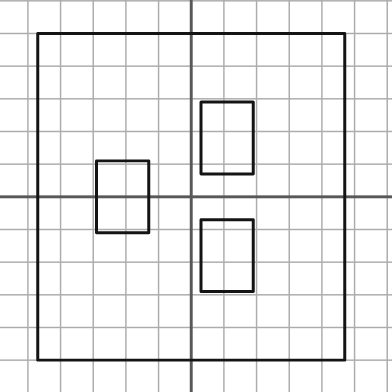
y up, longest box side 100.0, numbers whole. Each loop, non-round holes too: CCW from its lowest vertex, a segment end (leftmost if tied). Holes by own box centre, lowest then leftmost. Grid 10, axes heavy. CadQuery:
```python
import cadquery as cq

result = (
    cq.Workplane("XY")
    .moveTo(-47.0, -50.0)
    .lineTo(47.0, -50.0)
    .lineTo(47.0, 50.0)
    .lineTo(-47.0, 50.0)
    .close()
    .moveTo(3.0, -29.0)
    .lineTo(19.0, -29.0)
    .lineTo(19.0, -7.0)
    .lineTo(3.0, -7.0)
    .close()
    .moveTo(-29.0, -11.0)
    .lineTo(-13.0, -11.0)
    .lineTo(-13.0, 11.0)
    .lineTo(-29.0, 11.0)
    .close()
    .moveTo(3.0, 7.0)
    .lineTo(19.0, 7.0)
    .lineTo(19.0, 29.0)
    .lineTo(3.0, 29.0)
    .close()
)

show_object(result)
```